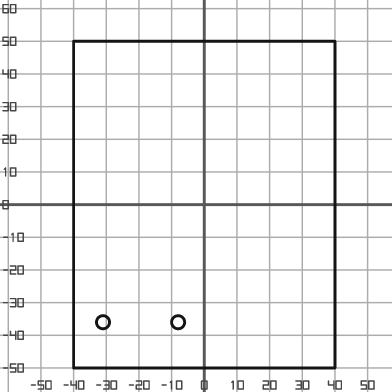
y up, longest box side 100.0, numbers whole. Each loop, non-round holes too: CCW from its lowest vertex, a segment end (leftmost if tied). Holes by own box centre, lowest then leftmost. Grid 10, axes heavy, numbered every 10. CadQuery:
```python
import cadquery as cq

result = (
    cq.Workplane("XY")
    .moveTo(-40.0, -50.0)
    .lineTo(40.0, -50.0)
    .lineTo(40.0, 50.0)
    .lineTo(-40.0, 50.0)
    .close()
    .moveTo(-31.0, -36.0)
    .circle(2.0)
    .moveTo(-8.0, -36.0)
    .circle(2.0)
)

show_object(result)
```